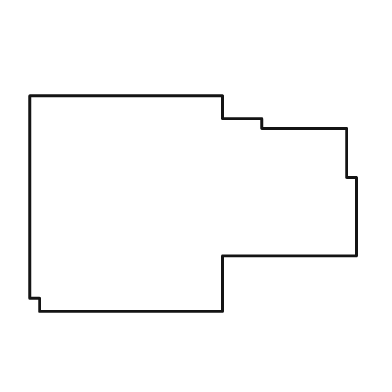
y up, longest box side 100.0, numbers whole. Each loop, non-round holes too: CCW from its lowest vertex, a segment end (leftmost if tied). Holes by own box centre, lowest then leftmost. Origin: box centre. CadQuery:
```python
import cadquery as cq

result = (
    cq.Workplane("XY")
    .moveTo(-47.0, -33.0)
    .lineTo(9.0, -33.0)
    .lineTo(9.0, -16.0)
    .lineTo(50.0, -16.0)
    .lineTo(50.0, 8.0)
    .lineTo(47.0, 8.0)
    .lineTo(47.0, 23.0)
    .lineTo(21.0, 23.0)
    .lineTo(21.0, 26.0)
    .lineTo(9.0, 26.0)
    .lineTo(9.0, 33.0)
    .lineTo(-50.0, 33.0)
    .lineTo(-50.0, -29.0)
    .lineTo(-47.0, -29.0)
    .close()
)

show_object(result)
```